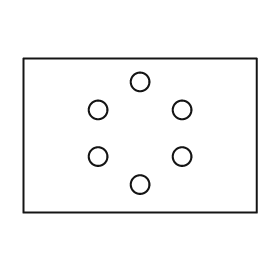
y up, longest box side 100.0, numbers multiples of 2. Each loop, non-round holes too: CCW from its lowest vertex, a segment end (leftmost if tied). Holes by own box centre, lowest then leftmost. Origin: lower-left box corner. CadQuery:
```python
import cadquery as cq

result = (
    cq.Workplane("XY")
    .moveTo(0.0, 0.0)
    .lineTo(100.0, 0.0)
    .lineTo(100.0, 66.0)
    .lineTo(0.0, 66.0)
    .close()
    .moveTo(50.0, 12.0)
    .circle(4.0)
    .moveTo(32.0, 24.0)
    .circle(4.0)
    .moveTo(68.0, 24.0)
    .circle(4.0)
    .moveTo(32.0, 44.0)
    .circle(4.0)
    .moveTo(68.0, 44.0)
    .circle(4.0)
    .moveTo(50.0, 56.0)
    .circle(4.0)
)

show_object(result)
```